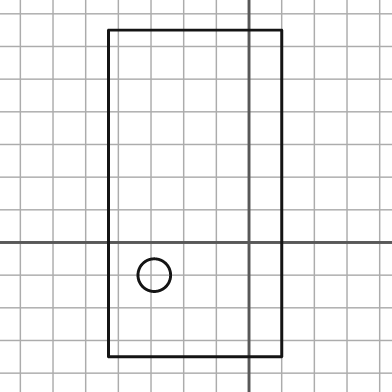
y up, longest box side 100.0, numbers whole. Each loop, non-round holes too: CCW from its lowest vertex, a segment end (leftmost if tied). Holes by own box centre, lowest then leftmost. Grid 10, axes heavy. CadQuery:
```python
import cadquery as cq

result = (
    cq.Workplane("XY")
    .moveTo(-43.0, -35.0)
    .lineTo(10.0, -35.0)
    .lineTo(10.0, 65.0)
    .lineTo(-43.0, 65.0)
    .close()
    .moveTo(-29.0, -10.0)
    .circle(5.0)
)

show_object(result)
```